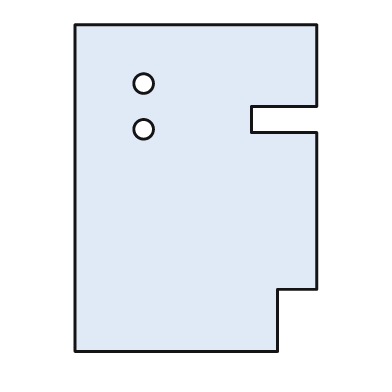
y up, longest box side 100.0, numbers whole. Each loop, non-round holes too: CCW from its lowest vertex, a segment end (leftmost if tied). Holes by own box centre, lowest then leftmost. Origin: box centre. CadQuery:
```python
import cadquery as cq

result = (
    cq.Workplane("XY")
    .moveTo(-37.0, -50.0)
    .lineTo(25.0, -50.0)
    .lineTo(25.0, -31.0)
    .lineTo(37.0, -31.0)
    .lineTo(37.0, 17.0)
    .lineTo(17.0, 17.0)
    .lineTo(17.0, 25.0)
    .lineTo(37.0, 25.0)
    .lineTo(37.0, 50.0)
    .lineTo(-37.0, 50.0)
    .close()
    .moveTo(-16.0, 18.0)
    .circle(3.0)
    .moveTo(-16.0, 32.0)
    .circle(3.0)
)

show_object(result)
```